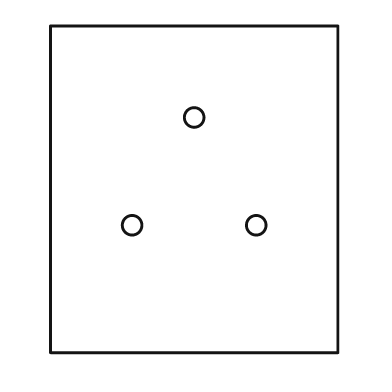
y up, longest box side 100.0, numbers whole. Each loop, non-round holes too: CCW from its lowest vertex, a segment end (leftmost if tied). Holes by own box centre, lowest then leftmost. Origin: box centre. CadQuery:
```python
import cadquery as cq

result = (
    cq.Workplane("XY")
    .moveTo(-44.0, -50.0)
    .lineTo(44.0, -50.0)
    .lineTo(44.0, 50.0)
    .lineTo(-44.0, 50.0)
    .close()
    .moveTo(-19.0, -11.0)
    .circle(3.0)
    .moveTo(19.0, -11.0)
    .circle(3.0)
    .moveTo(0.0, 22.0)
    .circle(3.0)
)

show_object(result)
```